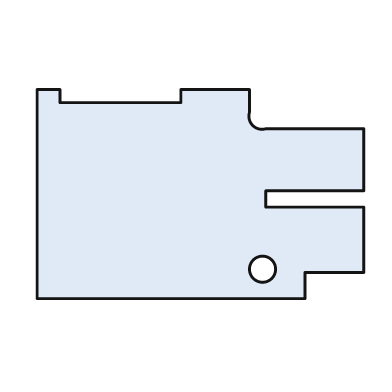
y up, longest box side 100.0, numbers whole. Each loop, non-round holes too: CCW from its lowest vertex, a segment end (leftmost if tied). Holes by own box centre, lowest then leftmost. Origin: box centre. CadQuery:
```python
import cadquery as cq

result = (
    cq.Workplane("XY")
    .moveTo(-50.0, -32.0)
    .lineTo(32.0, -32.0)
    .lineTo(32.0, -24.0)
    .lineTo(50.0, -24.0)
    .lineTo(50.0, -4.0)
    .lineTo(20.0, -4.0)
    .lineTo(20.0, 1.0)
    .lineTo(50.0, 1.0)
    .lineTo(50.0, 20.0)
    .lineTo(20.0, 20.0)
    .threePointArc((16.0, 21.0), (15.0, 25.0))
    .lineTo(15.0, 32.0)
    .lineTo(-6.0, 32.0)
    .lineTo(-6.0, 28.0)
    .lineTo(-43.0, 28.0)
    .lineTo(-43.0, 32.0)
    .lineTo(-50.0, 32.0)
    .close()
    .moveTo(19.0, -23.0)
    .circle(4.0)
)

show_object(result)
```